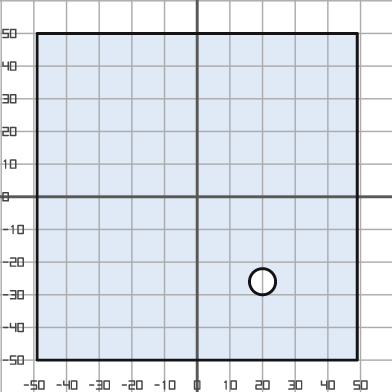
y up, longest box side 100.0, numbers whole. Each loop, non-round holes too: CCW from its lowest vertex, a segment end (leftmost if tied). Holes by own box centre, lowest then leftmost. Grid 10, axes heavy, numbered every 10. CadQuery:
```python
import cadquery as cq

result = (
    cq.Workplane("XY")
    .moveTo(-49.0, -50.0)
    .lineTo(49.0, -50.0)
    .lineTo(49.0, 50.0)
    .lineTo(-49.0, 50.0)
    .close()
    .moveTo(20.0, -26.0)
    .circle(4.0)
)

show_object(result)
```